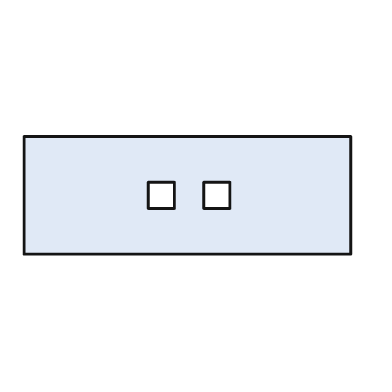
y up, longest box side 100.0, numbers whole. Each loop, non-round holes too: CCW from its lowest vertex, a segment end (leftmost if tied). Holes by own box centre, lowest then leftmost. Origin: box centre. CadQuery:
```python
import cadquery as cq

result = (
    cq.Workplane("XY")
    .moveTo(-50.0, -18.0)
    .lineTo(50.0, -18.0)
    .lineTo(50.0, 18.0)
    .lineTo(-50.0, 18.0)
    .close()
    .moveTo(-12.0, -4.0)
    .lineTo(-4.0, -4.0)
    .lineTo(-4.0, 4.0)
    .lineTo(-12.0, 4.0)
    .close()
    .moveTo(5.0, -4.0)
    .lineTo(13.0, -4.0)
    .lineTo(13.0, 4.0)
    .lineTo(5.0, 4.0)
    .close()
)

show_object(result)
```